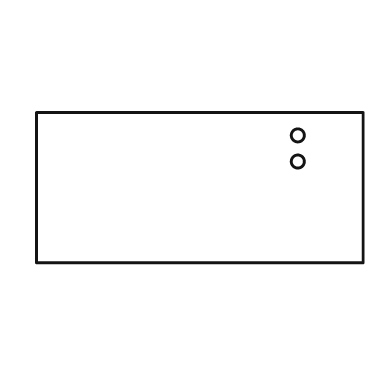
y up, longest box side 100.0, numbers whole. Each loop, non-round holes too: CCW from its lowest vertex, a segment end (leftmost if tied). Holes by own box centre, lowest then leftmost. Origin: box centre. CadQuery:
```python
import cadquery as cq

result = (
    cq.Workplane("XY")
    .moveTo(-50.0, -23.0)
    .lineTo(50.0, -23.0)
    .lineTo(50.0, 23.0)
    .lineTo(-50.0, 23.0)
    .close()
    .moveTo(30.0, 8.0)
    .circle(2.0)
    .moveTo(30.0, 16.0)
    .circle(2.0)
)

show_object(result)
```